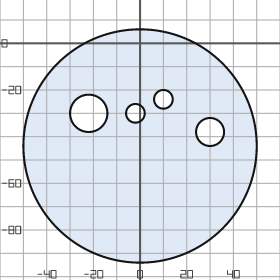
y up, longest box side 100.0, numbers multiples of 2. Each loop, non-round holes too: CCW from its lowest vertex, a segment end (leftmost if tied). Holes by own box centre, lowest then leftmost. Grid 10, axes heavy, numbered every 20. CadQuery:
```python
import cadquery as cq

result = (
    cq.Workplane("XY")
    .moveTo(0.0, -44.0)
    .circle(50.0)
    .moveTo(30.0, -38.0)
    .circle(6.0)
    .moveTo(-22.0, -30.0)
    .circle(8.0)
    .moveTo(-2.0, -30.0)
    .circle(4.0)
    .moveTo(10.0, -24.0)
    .circle(4.0)
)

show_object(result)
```